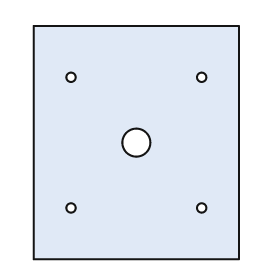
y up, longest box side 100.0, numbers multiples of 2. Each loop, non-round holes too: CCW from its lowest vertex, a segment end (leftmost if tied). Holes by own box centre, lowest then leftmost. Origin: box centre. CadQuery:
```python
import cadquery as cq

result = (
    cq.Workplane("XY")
    .moveTo(-44.0, -50.0)
    .lineTo(44.0, -50.0)
    .lineTo(44.0, 50.0)
    .lineTo(-44.0, 50.0)
    .close()
    .moveTo(-28.0, -28.0)
    .circle(2.0)
    .moveTo(28.0, -28.0)
    .circle(2.0)
    .moveTo(0.0, 0.0)
    .circle(6.0)
    .moveTo(-28.0, 28.0)
    .circle(2.0)
    .moveTo(28.0, 28.0)
    .circle(2.0)
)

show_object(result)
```